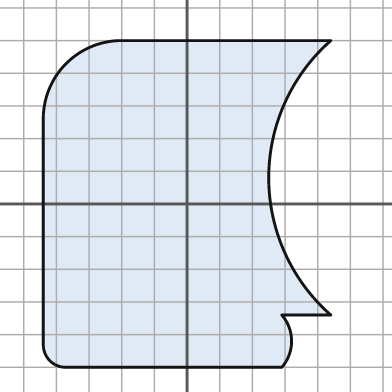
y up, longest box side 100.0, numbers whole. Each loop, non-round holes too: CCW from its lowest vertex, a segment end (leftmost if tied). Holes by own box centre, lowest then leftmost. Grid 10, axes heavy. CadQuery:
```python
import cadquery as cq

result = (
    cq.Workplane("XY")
    .moveTo(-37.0, -50.0)
    .lineTo(29.0, -50.0)
    .threePointArc((32.0, -42.0), (29.0, -34.0))
    .lineTo(44.0, -34.0)
    .threePointArc((25.0, 8.0), (44.0, 50.0))
    .lineTo(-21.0, 50.0)
    .threePointArc((-37.0, 43.0), (-44.0, 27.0))
    .lineTo(-44.0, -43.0)
    .threePointArc((-42.0, -48.0), (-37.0, -50.0))
    .close()
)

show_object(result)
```